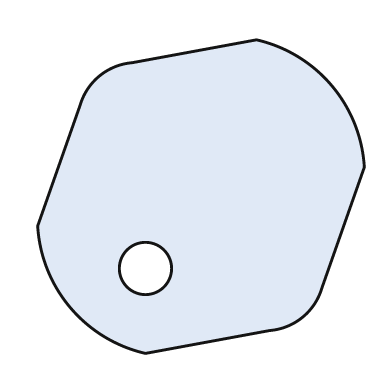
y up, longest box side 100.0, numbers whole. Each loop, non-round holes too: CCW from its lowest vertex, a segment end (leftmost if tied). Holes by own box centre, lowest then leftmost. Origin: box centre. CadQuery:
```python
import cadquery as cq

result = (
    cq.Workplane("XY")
    .moveTo(-17.0, -48.0)
    .lineTo(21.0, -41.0)
    .threePointArc((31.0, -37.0), (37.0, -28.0))
    .lineTo(50.0, 9.0)
    .threePointArc((40.0, 34.0), (17.0, 48.0))
    .lineTo(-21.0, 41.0)
    .threePointArc((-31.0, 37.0), (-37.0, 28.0))
    .lineTo(-50.0, -9.0)
    .threePointArc((-40.0, -34.0), (-17.0, -48.0))
    .close()
    .moveTo(-17.0, -22.0)
    .circle(8.0)
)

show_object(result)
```